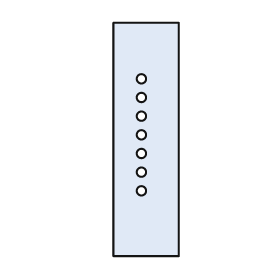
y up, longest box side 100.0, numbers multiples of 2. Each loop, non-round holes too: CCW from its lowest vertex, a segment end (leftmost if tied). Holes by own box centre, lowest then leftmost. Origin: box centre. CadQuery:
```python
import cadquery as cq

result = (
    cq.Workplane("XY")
    .moveTo(-14.0, -50.0)
    .lineTo(14.0, -50.0)
    .lineTo(14.0, 50.0)
    .lineTo(-14.0, 50.0)
    .close()
    .moveTo(-2.0, -22.0)
    .circle(2.0)
    .moveTo(-2.0, -14.0)
    .circle(2.0)
    .moveTo(-2.0, -6.0)
    .circle(2.0)
    .moveTo(-2.0, 2.0)
    .circle(2.0)
    .moveTo(-2.0, 10.0)
    .circle(2.0)
    .moveTo(-2.0, 18.0)
    .circle(2.0)
    .moveTo(-2.0, 26.0)
    .circle(2.0)
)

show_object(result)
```